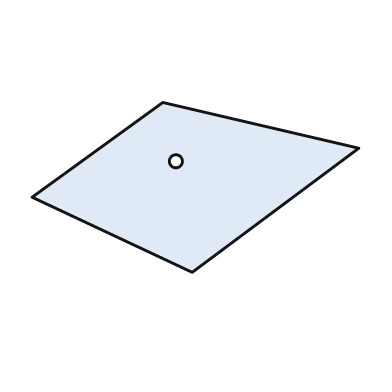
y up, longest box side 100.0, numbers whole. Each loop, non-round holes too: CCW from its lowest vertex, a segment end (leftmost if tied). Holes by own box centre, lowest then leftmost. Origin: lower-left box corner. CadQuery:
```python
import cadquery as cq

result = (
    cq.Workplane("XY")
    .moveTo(49.0, 0.0)
    .lineTo(100.0, 38.0)
    .lineTo(40.0, 52.0)
    .lineTo(0.0, 23.0)
    .close()
    .moveTo(44.0, 34.0)
    .circle(2.0)
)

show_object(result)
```